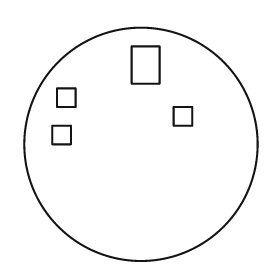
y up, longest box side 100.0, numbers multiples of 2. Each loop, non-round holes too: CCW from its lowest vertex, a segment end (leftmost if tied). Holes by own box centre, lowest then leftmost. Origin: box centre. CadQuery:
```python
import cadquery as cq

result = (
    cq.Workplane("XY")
    .moveTo(0.0, 0.0)
    .circle(50.0)
    .moveTo(-38.0, 0.0)
    .lineTo(-30.0, 0.0)
    .lineTo(-30.0, 8.0)
    .lineTo(-38.0, 8.0)
    .close()
    .moveTo(14.0, 8.0)
    .lineTo(22.0, 8.0)
    .lineTo(22.0, 16.0)
    .lineTo(14.0, 16.0)
    .close()
    .moveTo(-36.0, 16.0)
    .lineTo(-28.0, 16.0)
    .lineTo(-28.0, 24.0)
    .lineTo(-36.0, 24.0)
    .close()
    .moveTo(-4.0, 26.0)
    .lineTo(8.0, 26.0)
    .lineTo(8.0, 42.0)
    .lineTo(-4.0, 42.0)
    .close()
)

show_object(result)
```